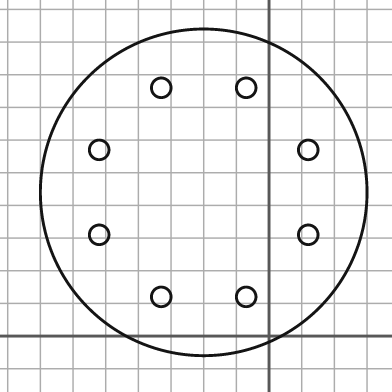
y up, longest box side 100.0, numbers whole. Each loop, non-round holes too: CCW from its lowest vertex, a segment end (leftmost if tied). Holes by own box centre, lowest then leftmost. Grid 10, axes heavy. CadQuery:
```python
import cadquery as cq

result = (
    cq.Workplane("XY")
    .moveTo(-20.0, 44.0)
    .circle(50.0)
    .moveTo(-33.0, 12.0)
    .circle(3.0)
    .moveTo(-7.0, 12.0)
    .circle(3.0)
    .moveTo(-52.0, 31.0)
    .circle(3.0)
    .moveTo(12.0, 31.0)
    .circle(3.0)
    .moveTo(-52.0, 57.0)
    .circle(3.0)
    .moveTo(12.0, 57.0)
    .circle(3.0)
    .moveTo(-33.0, 76.0)
    .circle(3.0)
    .moveTo(-7.0, 76.0)
    .circle(3.0)
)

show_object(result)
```